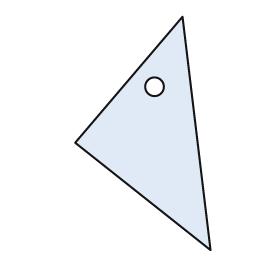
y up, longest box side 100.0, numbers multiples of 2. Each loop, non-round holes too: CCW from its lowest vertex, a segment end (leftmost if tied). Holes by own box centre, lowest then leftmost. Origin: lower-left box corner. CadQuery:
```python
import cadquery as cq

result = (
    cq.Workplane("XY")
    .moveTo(58.0, 0.0)
    .lineTo(46.0, 100.0)
    .lineTo(0.0, 46.0)
    .close()
    .moveTo(34.0, 70.0)
    .circle(4.0)
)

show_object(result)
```